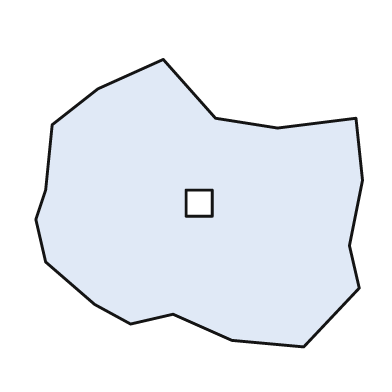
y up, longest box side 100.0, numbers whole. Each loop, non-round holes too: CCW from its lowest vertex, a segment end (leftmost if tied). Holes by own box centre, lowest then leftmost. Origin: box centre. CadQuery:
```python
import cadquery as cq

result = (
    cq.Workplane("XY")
    .moveTo(32.0, -44.0)
    .lineTo(49.0, -26.0)
    .lineTo(46.0, -13.0)
    .lineTo(50.0, 7.0)
    .lineTo(48.0, 26.0)
    .lineTo(24.0, 23.0)
    .lineTo(5.0, 26.0)
    .lineTo(-11.0, 44.0)
    .lineTo(-31.0, 35.0)
    .lineTo(-45.0, 24.0)
    .lineTo(-47.0, 4.0)
    .lineTo(-50.0, -5.0)
    .lineTo(-47.0, -18.0)
    .lineTo(-32.0, -31.0)
    .lineTo(-21.0, -37.0)
    .lineTo(-8.0, -34.0)
    .lineTo(10.0, -42.0)
    .close()
    .moveTo(-4.0, -4.0)
    .lineTo(4.0, -4.0)
    .lineTo(4.0, 4.0)
    .lineTo(-4.0, 4.0)
    .close()
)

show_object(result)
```